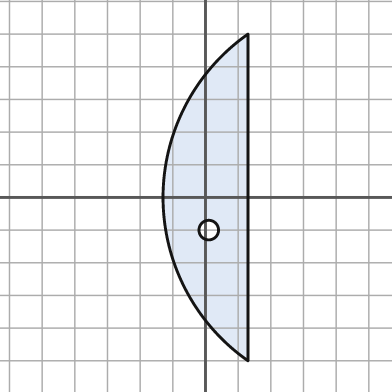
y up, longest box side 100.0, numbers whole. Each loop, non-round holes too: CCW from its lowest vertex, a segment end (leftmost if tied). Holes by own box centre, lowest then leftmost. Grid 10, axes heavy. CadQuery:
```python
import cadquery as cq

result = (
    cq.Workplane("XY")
    .moveTo(13.0, -50.0)
    .lineTo(13.0, 50.0)
    .threePointArc((-13.0, 0.0), (13.0, -50.0))
    .close()
    .moveTo(1.0, -10.0)
    .circle(3.0)
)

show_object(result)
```